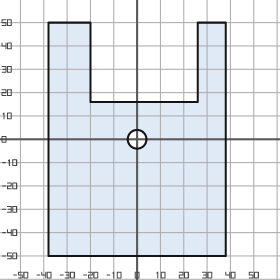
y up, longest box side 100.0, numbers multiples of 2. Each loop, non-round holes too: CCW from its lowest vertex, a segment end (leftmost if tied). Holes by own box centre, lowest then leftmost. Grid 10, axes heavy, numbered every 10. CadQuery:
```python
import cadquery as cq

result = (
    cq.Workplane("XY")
    .moveTo(-38.0, -50.0)
    .lineTo(38.0, -50.0)
    .lineTo(38.0, 50.0)
    .lineTo(26.0, 50.0)
    .lineTo(26.0, 16.0)
    .lineTo(-20.0, 16.0)
    .lineTo(-20.0, 50.0)
    .lineTo(-38.0, 50.0)
    .close()
    .moveTo(0.0, 0.0)
    .circle(4.0)
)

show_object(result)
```